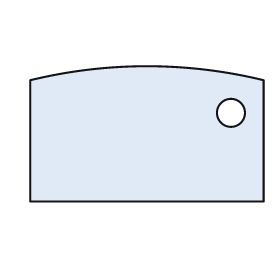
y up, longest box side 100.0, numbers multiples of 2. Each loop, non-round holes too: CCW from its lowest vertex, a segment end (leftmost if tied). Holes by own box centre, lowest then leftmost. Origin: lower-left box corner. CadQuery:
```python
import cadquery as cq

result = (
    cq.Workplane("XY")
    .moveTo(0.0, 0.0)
    .lineTo(100.0, 0.0)
    .lineTo(100.0, 52.0)
    .threePointArc((50.0, 58.0), (0.0, 52.0))
    .close()
    .moveTo(86.0, 38.0)
    .circle(6.0)
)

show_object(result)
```